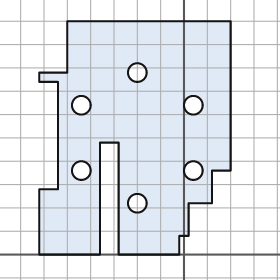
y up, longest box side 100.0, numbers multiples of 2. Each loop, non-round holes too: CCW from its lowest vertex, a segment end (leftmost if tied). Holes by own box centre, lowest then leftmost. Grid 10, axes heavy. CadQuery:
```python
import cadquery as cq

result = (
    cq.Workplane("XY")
    .moveTo(-62.0, 0.0)
    .lineTo(-36.0, 0.0)
    .lineTo(-36.0, 48.0)
    .lineTo(-28.0, 48.0)
    .lineTo(-28.0, 0.0)
    .lineTo(-2.0, 0.0)
    .lineTo(-2.0, 8.0)
    .lineTo(2.0, 8.0)
    .lineTo(2.0, 22.0)
    .lineTo(12.0, 22.0)
    .lineTo(12.0, 36.0)
    .lineTo(20.0, 36.0)
    .lineTo(20.0, 100.0)
    .lineTo(-50.0, 100.0)
    .lineTo(-50.0, 78.0)
    .lineTo(-62.0, 78.0)
    .lineTo(-62.0, 74.0)
    .lineTo(-54.0, 74.0)
    .lineTo(-54.0, 28.0)
    .lineTo(-62.0, 28.0)
    .close()
    .moveTo(-20.0, 22.0)
    .circle(4.0)
    .moveTo(-44.0, 36.0)
    .circle(4.0)
    .moveTo(4.0, 36.0)
    .circle(4.0)
    .moveTo(-44.0, 64.0)
    .circle(4.0)
    .moveTo(4.0, 64.0)
    .circle(4.0)
    .moveTo(-20.0, 78.0)
    .circle(4.0)
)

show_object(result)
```